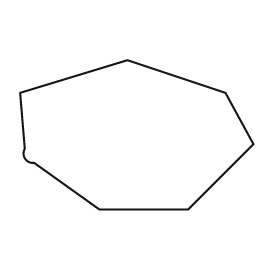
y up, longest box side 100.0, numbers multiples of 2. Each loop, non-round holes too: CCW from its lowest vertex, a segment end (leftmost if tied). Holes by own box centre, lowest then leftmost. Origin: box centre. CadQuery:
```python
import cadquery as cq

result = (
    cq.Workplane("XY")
    .moveTo(-16.0, -32.0)
    .lineTo(22.0, -32.0)
    .lineTo(50.0, -4.0)
    .lineTo(38.0, 18.0)
    .lineTo(-4.0, 32.0)
    .lineTo(-50.0, 18.0)
    .lineTo(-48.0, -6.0)
    .threePointArc((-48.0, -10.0), (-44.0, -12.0))
    .close()
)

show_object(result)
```